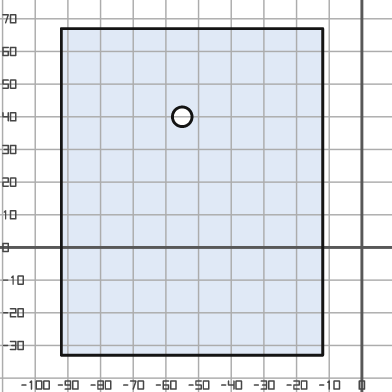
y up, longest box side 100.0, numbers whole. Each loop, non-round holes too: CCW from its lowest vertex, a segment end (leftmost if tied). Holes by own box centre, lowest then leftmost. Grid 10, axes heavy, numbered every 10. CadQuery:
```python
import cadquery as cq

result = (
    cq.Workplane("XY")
    .moveTo(-92.0, -33.0)
    .lineTo(-12.0, -33.0)
    .lineTo(-12.0, 67.0)
    .lineTo(-92.0, 67.0)
    .close()
    .moveTo(-55.0, 40.0)
    .circle(3.0)
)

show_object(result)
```